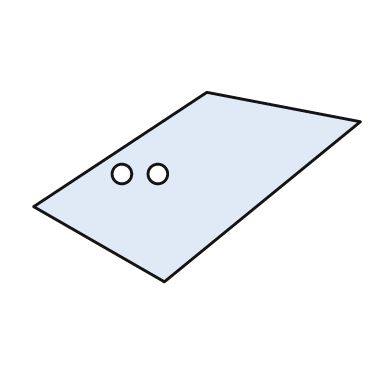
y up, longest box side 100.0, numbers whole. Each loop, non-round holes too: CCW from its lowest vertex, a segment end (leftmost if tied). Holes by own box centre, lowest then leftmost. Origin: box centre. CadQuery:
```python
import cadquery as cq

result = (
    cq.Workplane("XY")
    .moveTo(-10.0, -29.0)
    .lineTo(50.0, 20.0)
    .lineTo(3.0, 29.0)
    .lineTo(-50.0, -6.0)
    .close()
    .moveTo(-23.0, 4.0)
    .circle(3.0)
    .moveTo(-12.0, 4.0)
    .circle(3.0)
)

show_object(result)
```